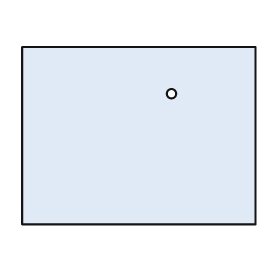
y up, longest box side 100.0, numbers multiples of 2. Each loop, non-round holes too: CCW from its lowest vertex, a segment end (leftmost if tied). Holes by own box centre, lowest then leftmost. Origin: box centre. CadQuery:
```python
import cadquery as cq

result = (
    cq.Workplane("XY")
    .moveTo(-50.0, -38.0)
    .lineTo(50.0, -38.0)
    .lineTo(50.0, 38.0)
    .lineTo(-50.0, 38.0)
    .close()
    .moveTo(14.0, 18.0)
    .circle(2.0)
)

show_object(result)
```